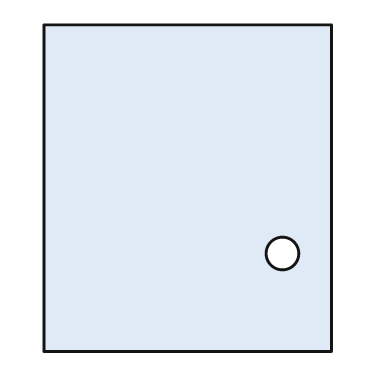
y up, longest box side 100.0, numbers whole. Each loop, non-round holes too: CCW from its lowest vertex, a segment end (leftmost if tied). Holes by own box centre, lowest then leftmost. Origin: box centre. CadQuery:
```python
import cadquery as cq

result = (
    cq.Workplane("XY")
    .moveTo(-44.0, -50.0)
    .lineTo(44.0, -50.0)
    .lineTo(44.0, 50.0)
    .lineTo(-44.0, 50.0)
    .close()
    .moveTo(29.0, -20.0)
    .circle(5.0)
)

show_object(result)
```